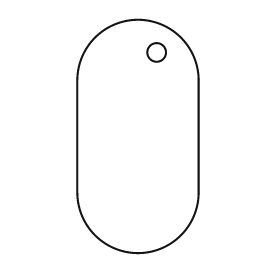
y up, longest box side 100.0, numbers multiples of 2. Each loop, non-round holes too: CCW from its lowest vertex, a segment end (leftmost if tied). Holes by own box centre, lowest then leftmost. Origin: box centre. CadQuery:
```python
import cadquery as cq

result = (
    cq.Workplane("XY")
    .moveTo(-26.0, -24.0)
    .threePointArc((0.0, -50.0), (26.0, -24.0))
    .lineTo(26.0, 24.0)
    .threePointArc((0.0, 50.0), (-26.0, 24.0))
    .close()
    .moveTo(8.0, 36.0)
    .circle(4.0)
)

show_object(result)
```